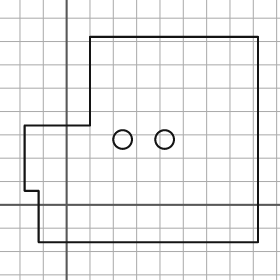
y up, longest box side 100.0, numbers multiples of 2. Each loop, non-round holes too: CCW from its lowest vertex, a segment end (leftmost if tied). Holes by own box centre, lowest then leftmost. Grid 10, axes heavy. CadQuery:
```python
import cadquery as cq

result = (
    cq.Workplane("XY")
    .moveTo(-12.0, -16.0)
    .lineTo(82.0, -16.0)
    .lineTo(82.0, 72.0)
    .lineTo(10.0, 72.0)
    .lineTo(10.0, 34.0)
    .lineTo(-18.0, 34.0)
    .lineTo(-18.0, 6.0)
    .lineTo(-12.0, 6.0)
    .close()
    .moveTo(24.0, 28.0)
    .circle(4.0)
    .moveTo(42.0, 28.0)
    .circle(4.0)
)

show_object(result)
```